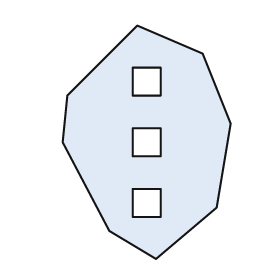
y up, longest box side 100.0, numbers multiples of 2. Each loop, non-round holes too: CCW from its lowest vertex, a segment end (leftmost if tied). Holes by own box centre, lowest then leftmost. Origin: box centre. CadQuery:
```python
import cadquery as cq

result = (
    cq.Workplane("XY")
    .moveTo(4.0, -50.0)
    .lineTo(30.0, -28.0)
    .lineTo(36.0, 8.0)
    .lineTo(24.0, 38.0)
    .lineTo(-4.0, 50.0)
    .lineTo(-34.0, 20.0)
    .lineTo(-36.0, 0.0)
    .lineTo(-16.0, -38.0)
    .close()
    .moveTo(-6.0, -32.0)
    .lineTo(6.0, -32.0)
    .lineTo(6.0, -20.0)
    .lineTo(-6.0, -20.0)
    .close()
    .moveTo(-6.0, -6.0)
    .lineTo(6.0, -6.0)
    .lineTo(6.0, 6.0)
    .lineTo(-6.0, 6.0)
    .close()
    .moveTo(-6.0, 20.0)
    .lineTo(6.0, 20.0)
    .lineTo(6.0, 32.0)
    .lineTo(-6.0, 32.0)
    .close()
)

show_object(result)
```